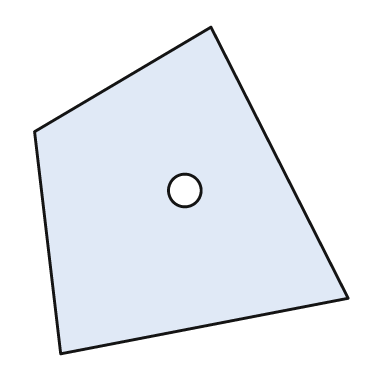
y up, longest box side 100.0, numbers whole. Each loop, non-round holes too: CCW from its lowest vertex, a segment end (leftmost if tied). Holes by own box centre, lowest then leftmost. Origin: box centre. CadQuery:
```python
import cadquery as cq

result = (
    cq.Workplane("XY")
    .moveTo(-40.0, -50.0)
    .lineTo(48.0, -33.0)
    .lineTo(6.0, 50.0)
    .lineTo(-48.0, 18.0)
    .close()
    .moveTo(-2.0, 0.0)
    .circle(5.0)
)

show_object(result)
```